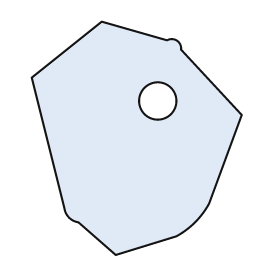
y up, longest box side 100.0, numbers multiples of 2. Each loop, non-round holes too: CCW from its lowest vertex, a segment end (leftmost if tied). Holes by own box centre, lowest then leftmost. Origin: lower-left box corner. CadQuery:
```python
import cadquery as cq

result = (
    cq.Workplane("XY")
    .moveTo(36.0, 0.0)
    .lineTo(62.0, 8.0)
    .threePointArc((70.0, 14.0), (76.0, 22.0))
    .lineTo(90.0, 60.0)
    .lineTo(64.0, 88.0)
    .threePointArc((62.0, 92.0), (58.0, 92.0))
    .lineTo(30.0, 100.0)
    .lineTo(0.0, 76.0)
    .lineTo(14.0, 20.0)
    .threePointArc((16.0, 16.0), (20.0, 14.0))
    .close()
    .moveTo(54.0, 66.0)
    .circle(8.0)
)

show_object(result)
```